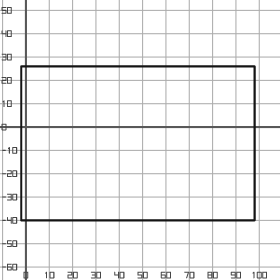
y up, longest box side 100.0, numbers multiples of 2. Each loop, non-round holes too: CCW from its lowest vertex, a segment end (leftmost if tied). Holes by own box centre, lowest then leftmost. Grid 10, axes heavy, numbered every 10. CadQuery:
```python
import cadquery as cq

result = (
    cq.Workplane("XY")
    .moveTo(-2.0, -40.0)
    .lineTo(98.0, -40.0)
    .lineTo(98.0, 26.0)
    .lineTo(-2.0, 26.0)
    .close()
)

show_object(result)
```